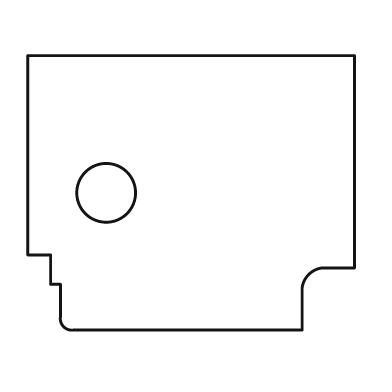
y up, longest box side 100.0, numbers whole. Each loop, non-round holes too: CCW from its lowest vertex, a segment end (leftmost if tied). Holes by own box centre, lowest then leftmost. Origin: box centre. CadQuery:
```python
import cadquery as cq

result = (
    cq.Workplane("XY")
    .moveTo(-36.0, -42.0)
    .lineTo(34.0, -42.0)
    .lineTo(34.0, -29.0)
    .threePointArc((36.0, -25.0), (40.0, -23.0))
    .lineTo(50.0, -23.0)
    .lineTo(50.0, 42.0)
    .lineTo(-50.0, 42.0)
    .lineTo(-50.0, -19.0)
    .lineTo(-43.0, -19.0)
    .lineTo(-43.0, -28.0)
    .lineTo(-40.0, -28.0)
    .lineTo(-40.0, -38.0)
    .threePointArc((-39.0, -41.0), (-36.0, -42.0))
    .close()
    .moveTo(-26.0, 0.0)
    .circle(9.0)
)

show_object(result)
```